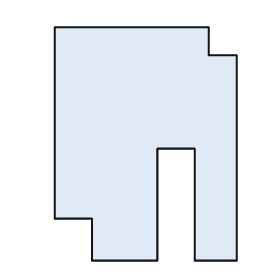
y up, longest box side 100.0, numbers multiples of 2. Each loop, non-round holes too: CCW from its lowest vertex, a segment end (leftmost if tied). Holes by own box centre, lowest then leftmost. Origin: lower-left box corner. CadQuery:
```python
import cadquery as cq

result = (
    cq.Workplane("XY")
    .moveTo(16.0, 0.0)
    .lineTo(44.0, 0.0)
    .lineTo(44.0, 48.0)
    .lineTo(60.0, 48.0)
    .lineTo(60.0, 0.0)
    .lineTo(78.0, 0.0)
    .lineTo(78.0, 88.0)
    .lineTo(66.0, 88.0)
    .lineTo(66.0, 100.0)
    .lineTo(0.0, 100.0)
    .lineTo(0.0, 18.0)
    .lineTo(16.0, 18.0)
    .close()
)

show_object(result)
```